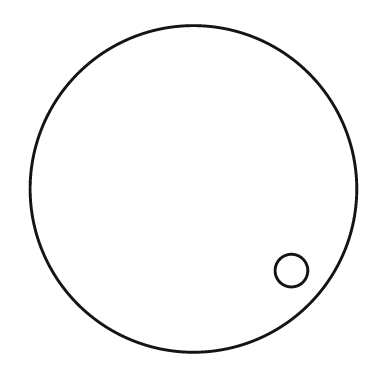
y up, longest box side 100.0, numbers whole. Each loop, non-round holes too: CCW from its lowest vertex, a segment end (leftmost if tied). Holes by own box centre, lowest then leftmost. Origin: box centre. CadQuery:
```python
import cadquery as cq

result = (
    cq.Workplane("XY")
    .moveTo(0.0, 0.0)
    .circle(50.0)
    .moveTo(30.0, -25.0)
    .circle(5.0)
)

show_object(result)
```